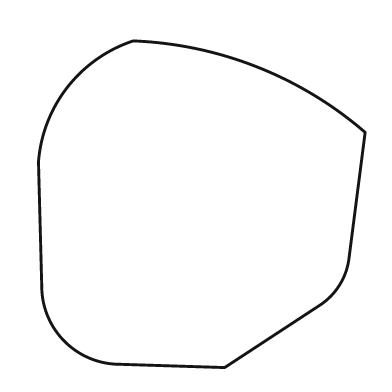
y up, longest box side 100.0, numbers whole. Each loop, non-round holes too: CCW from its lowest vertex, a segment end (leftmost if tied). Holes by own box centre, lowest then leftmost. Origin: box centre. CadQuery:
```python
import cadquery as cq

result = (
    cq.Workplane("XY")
    .moveTo(7.0, -50.0)
    .lineTo(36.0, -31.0)
    .threePointArc((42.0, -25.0), (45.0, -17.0))
    .lineTo(50.0, 22.0)
    .threePointArc((17.0, 42.0), (-21.0, 50.0))
    .threePointArc((-41.0, 36.0), (-50.0, 13.0))
    .lineTo(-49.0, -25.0)
    .threePointArc((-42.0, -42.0), (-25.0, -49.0))
    .close()
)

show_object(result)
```